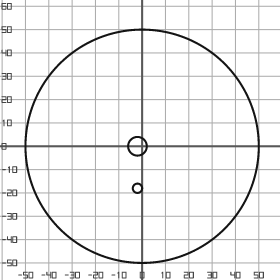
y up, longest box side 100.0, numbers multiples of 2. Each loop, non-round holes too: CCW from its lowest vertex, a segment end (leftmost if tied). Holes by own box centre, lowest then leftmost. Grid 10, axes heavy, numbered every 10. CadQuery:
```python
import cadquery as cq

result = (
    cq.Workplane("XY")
    .moveTo(0.0, 0.0)
    .circle(50.0)
    .moveTo(-2.0, -18.0)
    .circle(2.0)
    .moveTo(-2.0, 0.0)
    .circle(4.0)
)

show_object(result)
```